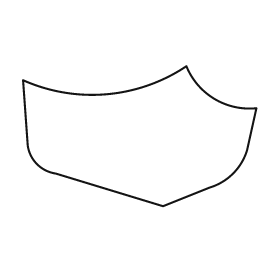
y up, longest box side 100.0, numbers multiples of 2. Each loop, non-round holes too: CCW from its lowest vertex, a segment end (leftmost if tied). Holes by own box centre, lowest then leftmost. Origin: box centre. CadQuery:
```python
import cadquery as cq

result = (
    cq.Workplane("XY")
    .moveTo(10.0, -30.0)
    .lineTo(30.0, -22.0)
    .threePointArc((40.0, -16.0), (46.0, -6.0))
    .lineTo(50.0, 12.0)
    .threePointArc((32.0, 16.0), (20.0, 30.0))
    .threePointArc((-14.0, 18.0), (-50.0, 24.0))
    .lineTo(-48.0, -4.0)
    .threePointArc((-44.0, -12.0), (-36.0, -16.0))
    .close()
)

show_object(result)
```